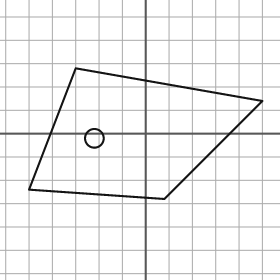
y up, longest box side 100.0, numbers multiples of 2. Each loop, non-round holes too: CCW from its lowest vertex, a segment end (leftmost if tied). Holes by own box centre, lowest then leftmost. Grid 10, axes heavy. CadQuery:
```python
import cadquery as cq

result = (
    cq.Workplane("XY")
    .moveTo(8.0, -28.0)
    .lineTo(50.0, 14.0)
    .lineTo(-30.0, 28.0)
    .lineTo(-50.0, -24.0)
    .close()
    .moveTo(-22.0, -2.0)
    .circle(4.0)
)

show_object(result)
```